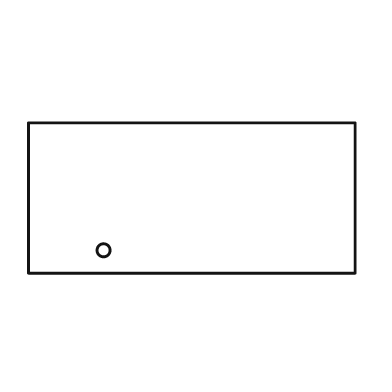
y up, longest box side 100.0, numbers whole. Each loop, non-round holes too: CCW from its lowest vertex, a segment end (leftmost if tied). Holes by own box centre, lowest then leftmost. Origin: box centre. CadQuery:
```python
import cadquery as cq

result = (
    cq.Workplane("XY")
    .moveTo(-50.0, -23.0)
    .lineTo(50.0, -23.0)
    .lineTo(50.0, 23.0)
    .lineTo(-50.0, 23.0)
    .close()
    .moveTo(-27.0, -16.0)
    .circle(2.0)
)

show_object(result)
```